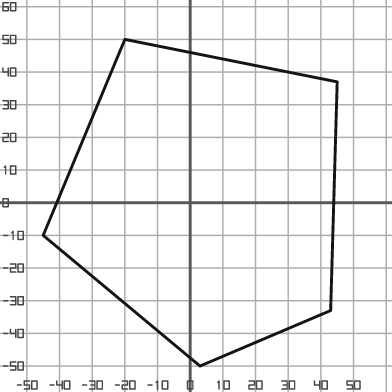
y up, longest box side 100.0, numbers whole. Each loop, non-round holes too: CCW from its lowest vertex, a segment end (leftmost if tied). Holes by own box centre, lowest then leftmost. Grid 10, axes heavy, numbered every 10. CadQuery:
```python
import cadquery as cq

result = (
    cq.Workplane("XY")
    .moveTo(3.0, -50.0)
    .lineTo(43.0, -33.0)
    .lineTo(45.0, 37.0)
    .lineTo(-20.0, 50.0)
    .lineTo(-45.0, -10.0)
    .close()
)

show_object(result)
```